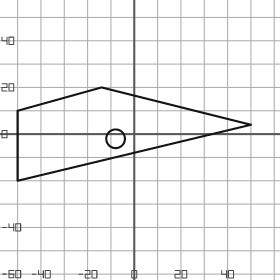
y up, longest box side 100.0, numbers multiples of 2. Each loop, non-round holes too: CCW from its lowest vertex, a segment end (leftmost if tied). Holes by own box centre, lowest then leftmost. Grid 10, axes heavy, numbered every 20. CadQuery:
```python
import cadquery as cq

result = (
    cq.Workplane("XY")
    .moveTo(-50.0, -20.0)
    .lineTo(50.0, 4.0)
    .lineTo(-14.0, 20.0)
    .lineTo(-50.0, 10.0)
    .close()
    .moveTo(-8.0, -2.0)
    .circle(4.0)
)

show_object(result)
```